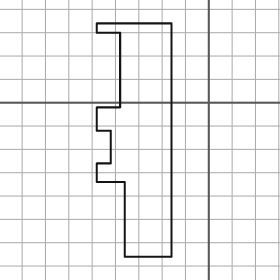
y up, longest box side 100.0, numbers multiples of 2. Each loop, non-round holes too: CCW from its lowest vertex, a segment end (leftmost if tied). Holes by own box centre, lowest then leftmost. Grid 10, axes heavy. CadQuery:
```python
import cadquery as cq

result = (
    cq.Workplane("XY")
    .moveTo(-36.0, -66.0)
    .lineTo(-16.0, -66.0)
    .lineTo(-16.0, 34.0)
    .lineTo(-48.0, 34.0)
    .lineTo(-48.0, 30.0)
    .lineTo(-38.0, 30.0)
    .lineTo(-38.0, -2.0)
    .lineTo(-48.0, -2.0)
    .lineTo(-48.0, -12.0)
    .lineTo(-42.0, -12.0)
    .lineTo(-42.0, -26.0)
    .lineTo(-48.0, -26.0)
    .lineTo(-48.0, -34.0)
    .lineTo(-36.0, -34.0)
    .close()
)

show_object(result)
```